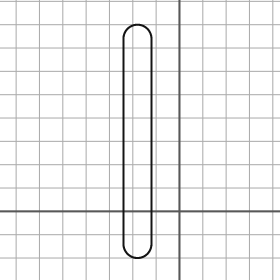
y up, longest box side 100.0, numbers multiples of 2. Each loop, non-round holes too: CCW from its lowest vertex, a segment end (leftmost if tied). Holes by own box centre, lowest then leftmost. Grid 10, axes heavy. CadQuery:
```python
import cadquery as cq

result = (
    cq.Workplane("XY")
    .moveTo(-24.0, -14.0)
    .threePointArc((-18.0, -20.0), (-12.0, -14.0))
    .lineTo(-12.0, 74.0)
    .threePointArc((-18.0, 80.0), (-24.0, 74.0))
    .close()
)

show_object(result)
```